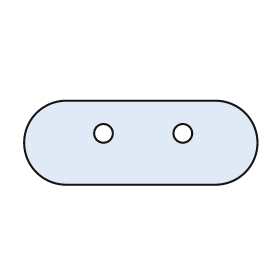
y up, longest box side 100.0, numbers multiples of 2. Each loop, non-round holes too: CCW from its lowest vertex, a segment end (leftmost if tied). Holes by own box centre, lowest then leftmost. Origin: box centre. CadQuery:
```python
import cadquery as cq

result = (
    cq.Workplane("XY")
    .moveTo(-32.0, -18.0)
    .lineTo(32.0, -18.0)
    .threePointArc((50.0, 0.0), (32.0, 18.0))
    .lineTo(-32.0, 18.0)
    .threePointArc((-50.0, 0.0), (-32.0, -18.0))
    .close()
    .moveTo(-16.0, 4.0)
    .circle(4.0)
    .moveTo(18.0, 4.0)
    .circle(4.0)
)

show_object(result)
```